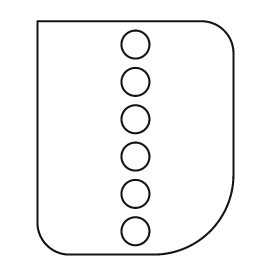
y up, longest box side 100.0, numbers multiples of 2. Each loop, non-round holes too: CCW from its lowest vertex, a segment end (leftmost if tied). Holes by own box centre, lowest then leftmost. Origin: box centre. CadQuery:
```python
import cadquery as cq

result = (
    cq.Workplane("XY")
    .moveTo(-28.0, -50.0)
    .lineTo(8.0, -50.0)
    .threePointArc((32.0, -40.0), (42.0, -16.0))
    .lineTo(42.0, 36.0)
    .threePointArc((38.0, 46.0), (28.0, 50.0))
    .lineTo(-42.0, 50.0)
    .lineTo(-42.0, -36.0)
    .threePointArc((-38.0, -46.0), (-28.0, -50.0))
    .close()
    .moveTo(0.0, -40.0)
    .circle(6.0)
    .moveTo(0.0, -24.0)
    .circle(6.0)
    .moveTo(0.0, -8.0)
    .circle(6.0)
    .moveTo(0.0, 8.0)
    .circle(6.0)
    .moveTo(0.0, 24.0)
    .circle(6.0)
    .moveTo(0.0, 40.0)
    .circle(6.0)
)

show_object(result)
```